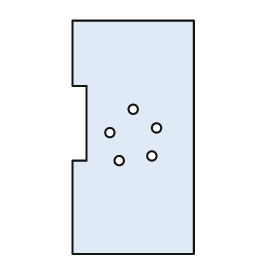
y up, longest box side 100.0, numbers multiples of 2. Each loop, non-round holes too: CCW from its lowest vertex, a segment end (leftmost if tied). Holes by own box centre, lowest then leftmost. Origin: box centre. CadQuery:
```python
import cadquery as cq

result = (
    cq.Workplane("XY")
    .moveTo(-26.0, -50.0)
    .lineTo(26.0, -50.0)
    .lineTo(26.0, 50.0)
    .lineTo(-26.0, 50.0)
    .lineTo(-26.0, 22.0)
    .lineTo(-20.0, 22.0)
    .lineTo(-20.0, -10.0)
    .lineTo(-26.0, -10.0)
    .close()
    .moveTo(-6.0, -10.0)
    .circle(2.0)
    .moveTo(8.0, -8.0)
    .circle(2.0)
    .moveTo(-10.0, 2.0)
    .circle(2.0)
    .moveTo(10.0, 4.0)
    .circle(2.0)
    .moveTo(0.0, 12.0)
    .circle(2.0)
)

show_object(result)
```